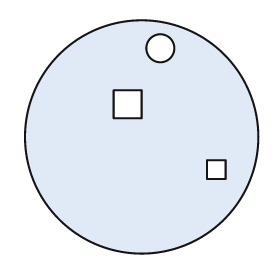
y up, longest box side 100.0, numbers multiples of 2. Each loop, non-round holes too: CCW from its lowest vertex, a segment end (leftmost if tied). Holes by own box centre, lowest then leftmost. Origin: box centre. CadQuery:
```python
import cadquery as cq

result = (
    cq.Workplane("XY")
    .moveTo(0.0, 0.0)
    .circle(50.0)
    .moveTo(28.0, -18.0)
    .lineTo(36.0, -18.0)
    .lineTo(36.0, -10.0)
    .lineTo(28.0, -10.0)
    .close()
    .moveTo(-12.0, 8.0)
    .lineTo(0.0, 8.0)
    .lineTo(0.0, 20.0)
    .lineTo(-12.0, 20.0)
    .close()
    .moveTo(8.0, 38.0)
    .circle(6.0)
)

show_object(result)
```